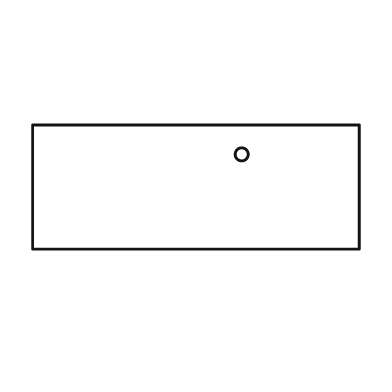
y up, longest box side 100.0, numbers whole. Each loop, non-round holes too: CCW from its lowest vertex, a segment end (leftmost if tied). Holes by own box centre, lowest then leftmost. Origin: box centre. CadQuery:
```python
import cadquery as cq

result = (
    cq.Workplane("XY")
    .moveTo(-50.0, -19.0)
    .lineTo(50.0, -19.0)
    .lineTo(50.0, 19.0)
    .lineTo(-50.0, 19.0)
    .close()
    .moveTo(14.0, 10.0)
    .circle(2.0)
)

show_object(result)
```